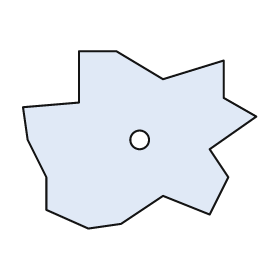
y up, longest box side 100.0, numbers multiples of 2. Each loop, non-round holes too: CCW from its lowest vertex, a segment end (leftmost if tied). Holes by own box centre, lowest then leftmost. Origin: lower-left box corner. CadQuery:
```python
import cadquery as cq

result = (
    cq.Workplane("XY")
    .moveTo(28.0, 0.0)
    .lineTo(42.0, 2.0)
    .lineTo(60.0, 14.0)
    .lineTo(80.0, 6.0)
    .lineTo(88.0, 22.0)
    .lineTo(80.0, 34.0)
    .lineTo(100.0, 48.0)
    .lineTo(86.0, 56.0)
    .lineTo(86.0, 72.0)
    .lineTo(60.0, 64.0)
    .lineTo(40.0, 76.0)
    .lineTo(24.0, 76.0)
    .lineTo(24.0, 54.0)
    .lineTo(0.0, 52.0)
    .lineTo(2.0, 38.0)
    .lineTo(10.0, 22.0)
    .lineTo(10.0, 8.0)
    .close()
    .moveTo(50.0, 38.0)
    .circle(4.0)
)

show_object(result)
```